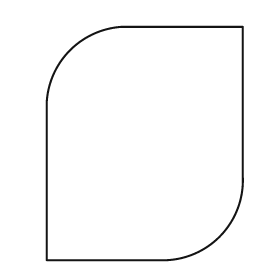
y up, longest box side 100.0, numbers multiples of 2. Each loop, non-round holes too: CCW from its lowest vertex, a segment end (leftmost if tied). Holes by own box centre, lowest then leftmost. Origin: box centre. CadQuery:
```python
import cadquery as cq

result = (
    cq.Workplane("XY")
    .moveTo(-42.0, -50.0)
    .lineTo(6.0, -50.0)
    .threePointArc((32.0, -40.0), (42.0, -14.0))
    .lineTo(42.0, 50.0)
    .lineTo(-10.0, 50.0)
    .threePointArc((-32.0, 40.0), (-42.0, 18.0))
    .close()
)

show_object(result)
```